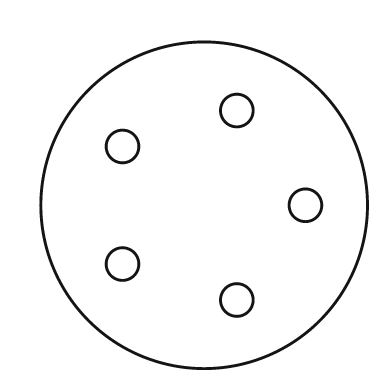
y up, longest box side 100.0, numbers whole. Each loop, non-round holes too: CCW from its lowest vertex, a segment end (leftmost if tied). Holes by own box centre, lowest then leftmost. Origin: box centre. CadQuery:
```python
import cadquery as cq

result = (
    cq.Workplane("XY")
    .moveTo(0.0, 0.0)
    .circle(50.0)
    .moveTo(10.0, -29.0)
    .circle(5.0)
    .moveTo(-25.0, -18.0)
    .circle(5.0)
    .moveTo(31.0, 0.0)
    .circle(5.0)
    .moveTo(-25.0, 18.0)
    .circle(5.0)
    .moveTo(10.0, 29.0)
    .circle(5.0)
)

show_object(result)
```